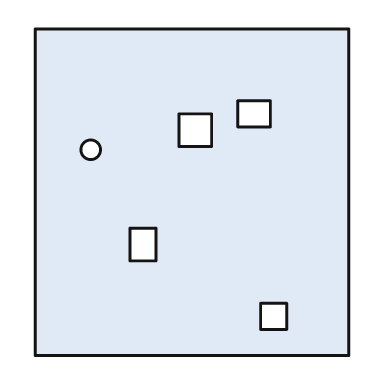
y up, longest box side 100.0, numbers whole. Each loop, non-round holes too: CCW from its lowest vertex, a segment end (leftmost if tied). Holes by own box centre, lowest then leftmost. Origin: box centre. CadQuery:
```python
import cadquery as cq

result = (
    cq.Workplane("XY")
    .moveTo(-48.0, -50.0)
    .lineTo(48.0, -50.0)
    .lineTo(48.0, 50.0)
    .lineTo(-48.0, 50.0)
    .close()
    .moveTo(21.0, -42.0)
    .lineTo(29.0, -42.0)
    .lineTo(29.0, -34.0)
    .lineTo(21.0, -34.0)
    .close()
    .moveTo(-19.0, -21.0)
    .lineTo(-11.0, -21.0)
    .lineTo(-11.0, -11.0)
    .lineTo(-19.0, -11.0)
    .close()
    .moveTo(-31.0, 13.0)
    .circle(3.0)
    .moveTo(-4.0, 14.0)
    .lineTo(6.0, 14.0)
    .lineTo(6.0, 24.0)
    .lineTo(-4.0, 24.0)
    .close()
    .moveTo(14.0, 20.0)
    .lineTo(24.0, 20.0)
    .lineTo(24.0, 28.0)
    .lineTo(14.0, 28.0)
    .close()
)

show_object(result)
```